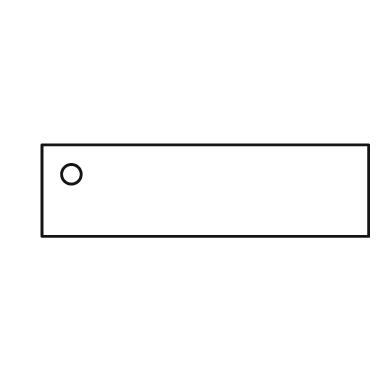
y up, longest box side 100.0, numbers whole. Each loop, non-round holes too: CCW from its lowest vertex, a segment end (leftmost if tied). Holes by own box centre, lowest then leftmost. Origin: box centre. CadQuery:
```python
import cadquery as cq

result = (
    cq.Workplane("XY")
    .moveTo(-50.0, -14.0)
    .lineTo(50.0, -14.0)
    .lineTo(50.0, 14.0)
    .lineTo(-50.0, 14.0)
    .close()
    .moveTo(-41.0, 5.0)
    .circle(3.0)
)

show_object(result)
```